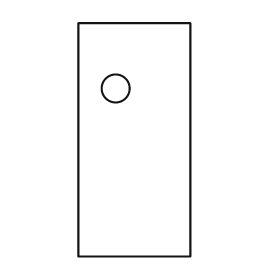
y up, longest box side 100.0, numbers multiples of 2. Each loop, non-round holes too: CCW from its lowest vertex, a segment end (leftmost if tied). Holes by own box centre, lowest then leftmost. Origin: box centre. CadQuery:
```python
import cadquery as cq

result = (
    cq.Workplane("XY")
    .moveTo(-24.0, -50.0)
    .lineTo(24.0, -50.0)
    .lineTo(24.0, 50.0)
    .lineTo(-24.0, 50.0)
    .close()
    .moveTo(-8.0, 22.0)
    .circle(6.0)
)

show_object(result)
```